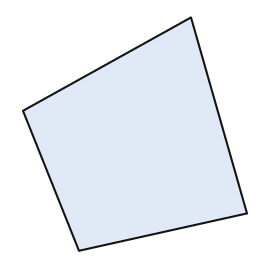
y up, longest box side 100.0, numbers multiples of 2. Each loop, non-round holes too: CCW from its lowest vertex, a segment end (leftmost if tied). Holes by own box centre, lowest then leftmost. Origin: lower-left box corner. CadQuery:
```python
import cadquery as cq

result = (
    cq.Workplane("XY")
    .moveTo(24.0, 0.0)
    .lineTo(96.0, 16.0)
    .lineTo(72.0, 100.0)
    .lineTo(0.0, 60.0)
    .close()
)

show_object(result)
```